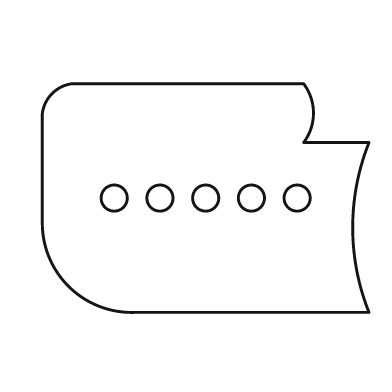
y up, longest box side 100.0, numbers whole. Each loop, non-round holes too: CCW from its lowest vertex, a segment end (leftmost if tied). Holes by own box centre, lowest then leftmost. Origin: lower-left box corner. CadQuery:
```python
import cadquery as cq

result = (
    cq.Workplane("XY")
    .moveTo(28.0, 0.0)
    .lineTo(100.0, 0.0)
    .threePointArc((95.0, 26.0), (100.0, 52.0))
    .lineTo(80.0, 52.0)
    .threePointArc((83.0, 61.0), (80.0, 70.0))
    .lineTo(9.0, 70.0)
    .threePointArc((3.0, 67.0), (0.0, 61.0))
    .lineTo(0.0, 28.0)
    .threePointArc((8.0, 8.0), (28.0, 0.0))
    .close()
    .moveTo(22.0, 35.0)
    .circle(4.0)
    .moveTo(36.0, 35.0)
    .circle(4.0)
    .moveTo(50.0, 35.0)
    .circle(4.0)
    .moveTo(64.0, 35.0)
    .circle(4.0)
    .moveTo(78.0, 35.0)
    .circle(4.0)
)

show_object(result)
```